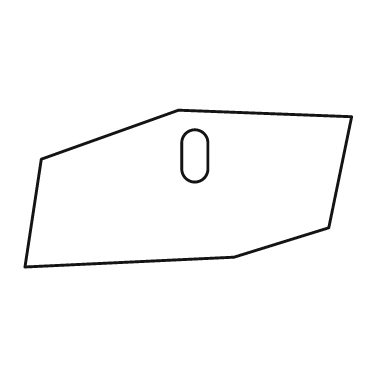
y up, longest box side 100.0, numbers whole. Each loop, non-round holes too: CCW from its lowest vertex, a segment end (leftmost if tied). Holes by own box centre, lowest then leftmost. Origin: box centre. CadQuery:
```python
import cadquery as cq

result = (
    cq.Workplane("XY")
    .moveTo(-50.0, -24.0)
    .lineTo(14.0, -21.0)
    .lineTo(43.0, -12.0)
    .lineTo(50.0, 22.0)
    .lineTo(-3.0, 24.0)
    .lineTo(-45.0, 9.0)
    .close()
    .moveTo(-2.0, 6.0)
    .threePointArc((2.0, 2.0), (6.0, 6.0))
    .lineTo(6.0, 14.0)
    .threePointArc((2.0, 18.0), (-2.0, 14.0))
    .close()
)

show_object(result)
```